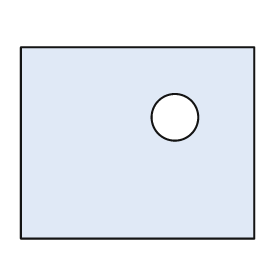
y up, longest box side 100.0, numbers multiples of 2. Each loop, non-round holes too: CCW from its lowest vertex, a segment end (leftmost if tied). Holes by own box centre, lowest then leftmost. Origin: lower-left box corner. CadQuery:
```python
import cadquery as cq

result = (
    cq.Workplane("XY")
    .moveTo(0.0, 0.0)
    .lineTo(100.0, 0.0)
    .lineTo(100.0, 82.0)
    .lineTo(0.0, 82.0)
    .close()
    .moveTo(66.0, 52.0)
    .circle(10.0)
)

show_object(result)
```